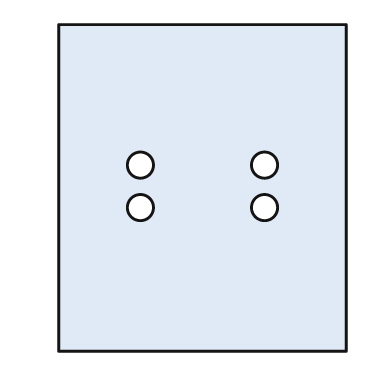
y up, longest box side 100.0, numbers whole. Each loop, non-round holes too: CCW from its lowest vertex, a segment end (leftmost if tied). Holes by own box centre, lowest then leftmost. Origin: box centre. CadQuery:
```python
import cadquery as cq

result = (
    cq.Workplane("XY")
    .moveTo(-44.0, -50.0)
    .lineTo(44.0, -50.0)
    .lineTo(44.0, 50.0)
    .lineTo(-44.0, 50.0)
    .close()
    .moveTo(-19.0, -6.0)
    .circle(4.0)
    .moveTo(19.0, -6.0)
    .circle(4.0)
    .moveTo(-19.0, 7.0)
    .circle(4.0)
    .moveTo(19.0, 7.0)
    .circle(4.0)
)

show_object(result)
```